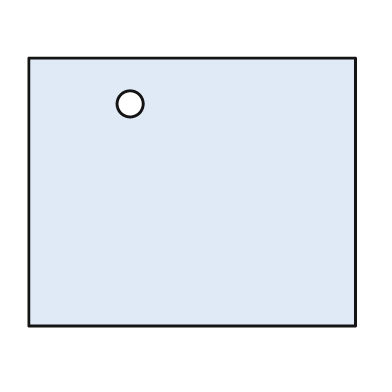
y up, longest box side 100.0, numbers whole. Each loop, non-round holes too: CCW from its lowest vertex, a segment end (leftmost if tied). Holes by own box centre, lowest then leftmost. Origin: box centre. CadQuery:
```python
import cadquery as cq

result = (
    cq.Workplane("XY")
    .moveTo(-50.0, -41.0)
    .lineTo(50.0, -41.0)
    .lineTo(50.0, 41.0)
    .lineTo(-50.0, 41.0)
    .close()
    .moveTo(-19.0, 27.0)
    .circle(4.0)
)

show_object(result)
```